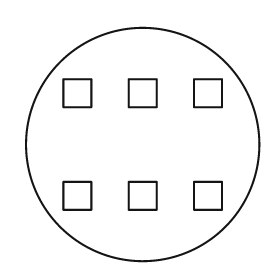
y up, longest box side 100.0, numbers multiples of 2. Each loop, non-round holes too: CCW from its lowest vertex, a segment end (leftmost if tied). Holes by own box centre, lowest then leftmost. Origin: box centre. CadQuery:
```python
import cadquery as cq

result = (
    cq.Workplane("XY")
    .moveTo(0.0, 0.0)
    .circle(50.0)
    .moveTo(-34.0, -28.0)
    .lineTo(-22.0, -28.0)
    .lineTo(-22.0, -16.0)
    .lineTo(-34.0, -16.0)
    .close()
    .moveTo(-6.0, -28.0)
    .lineTo(6.0, -28.0)
    .lineTo(6.0, -16.0)
    .lineTo(-6.0, -16.0)
    .close()
    .moveTo(22.0, -28.0)
    .lineTo(34.0, -28.0)
    .lineTo(34.0, -16.0)
    .lineTo(22.0, -16.0)
    .close()
    .moveTo(-34.0, 16.0)
    .lineTo(-22.0, 16.0)
    .lineTo(-22.0, 28.0)
    .lineTo(-34.0, 28.0)
    .close()
    .moveTo(-6.0, 16.0)
    .lineTo(6.0, 16.0)
    .lineTo(6.0, 28.0)
    .lineTo(-6.0, 28.0)
    .close()
    .moveTo(22.0, 16.0)
    .lineTo(34.0, 16.0)
    .lineTo(34.0, 28.0)
    .lineTo(22.0, 28.0)
    .close()
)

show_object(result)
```